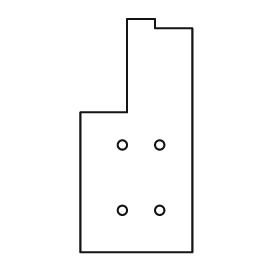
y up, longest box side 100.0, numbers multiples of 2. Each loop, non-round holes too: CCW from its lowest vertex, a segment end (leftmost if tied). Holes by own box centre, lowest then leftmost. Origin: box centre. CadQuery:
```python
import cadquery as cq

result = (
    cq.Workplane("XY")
    .moveTo(-24.0, -50.0)
    .lineTo(24.0, -50.0)
    .lineTo(24.0, 46.0)
    .lineTo(8.0, 46.0)
    .lineTo(8.0, 50.0)
    .lineTo(-4.0, 50.0)
    .lineTo(-4.0, 10.0)
    .lineTo(-24.0, 10.0)
    .close()
    .moveTo(-6.0, -32.0)
    .circle(2.0)
    .moveTo(10.0, -32.0)
    .circle(2.0)
    .moveTo(-6.0, -4.0)
    .circle(2.0)
    .moveTo(10.0, -4.0)
    .circle(2.0)
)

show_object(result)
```